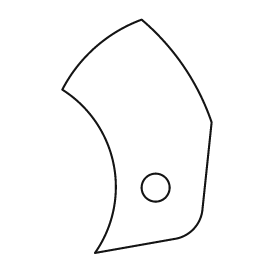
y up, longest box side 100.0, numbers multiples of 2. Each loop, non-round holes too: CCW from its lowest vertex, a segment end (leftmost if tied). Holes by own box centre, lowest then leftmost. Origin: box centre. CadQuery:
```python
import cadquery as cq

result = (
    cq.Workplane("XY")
    .moveTo(-18.0, -50.0)
    .lineTo(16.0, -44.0)
    .threePointArc((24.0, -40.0), (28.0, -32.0))
    .lineTo(32.0, 6.0)
    .threePointArc((20.0, 30.0), (2.0, 50.0))
    .threePointArc((-18.0, 38.0), (-32.0, 20.0))
    .threePointArc((-10.0, -12.0), (-18.0, -50.0))
    .close()
    .moveTo(8.0, -22.0)
    .circle(6.0)
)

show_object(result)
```